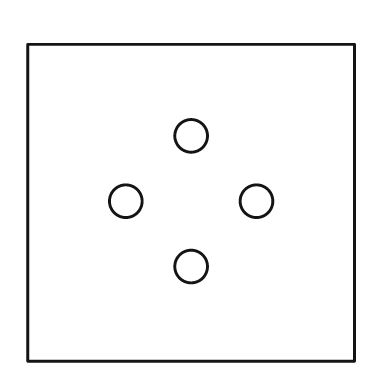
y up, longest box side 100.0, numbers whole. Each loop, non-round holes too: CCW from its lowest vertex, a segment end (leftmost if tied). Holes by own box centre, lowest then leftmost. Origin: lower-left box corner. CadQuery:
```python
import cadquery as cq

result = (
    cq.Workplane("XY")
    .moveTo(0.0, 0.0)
    .lineTo(100.0, 0.0)
    .lineTo(100.0, 97.0)
    .lineTo(0.0, 97.0)
    .close()
    .moveTo(50.0, 29.0)
    .circle(5.0)
    .moveTo(30.0, 49.0)
    .circle(5.0)
    .moveTo(70.0, 49.0)
    .circle(5.0)
    .moveTo(50.0, 69.0)
    .circle(5.0)
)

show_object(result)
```